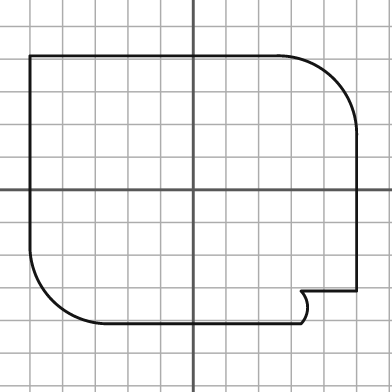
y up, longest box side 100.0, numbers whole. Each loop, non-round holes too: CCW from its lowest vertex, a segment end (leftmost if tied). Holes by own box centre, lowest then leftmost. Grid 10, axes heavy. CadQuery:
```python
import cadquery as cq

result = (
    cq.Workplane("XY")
    .moveTo(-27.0, -41.0)
    .lineTo(33.0, -41.0)
    .threePointArc((35.0, -36.0), (33.0, -31.0))
    .lineTo(50.0, -31.0)
    .lineTo(50.0, 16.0)
    .threePointArc((43.0, 34.0), (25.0, 41.0))
    .lineTo(-50.0, 41.0)
    .lineTo(-50.0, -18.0)
    .threePointArc((-43.0, -34.0), (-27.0, -41.0))
    .close()
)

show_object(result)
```